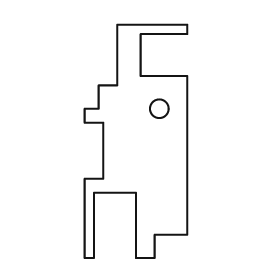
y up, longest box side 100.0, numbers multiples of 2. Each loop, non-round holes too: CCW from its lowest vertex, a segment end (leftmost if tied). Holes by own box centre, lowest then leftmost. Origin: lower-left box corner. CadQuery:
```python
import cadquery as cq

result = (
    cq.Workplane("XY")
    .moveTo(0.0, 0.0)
    .lineTo(4.0, 0.0)
    .lineTo(4.0, 28.0)
    .lineTo(22.0, 28.0)
    .lineTo(22.0, 0.0)
    .lineTo(30.0, 0.0)
    .lineTo(30.0, 10.0)
    .lineTo(44.0, 10.0)
    .lineTo(44.0, 78.0)
    .lineTo(24.0, 78.0)
    .lineTo(24.0, 96.0)
    .lineTo(44.0, 96.0)
    .lineTo(44.0, 100.0)
    .lineTo(14.0, 100.0)
    .lineTo(14.0, 74.0)
    .lineTo(6.0, 74.0)
    .lineTo(6.0, 64.0)
    .lineTo(0.0, 64.0)
    .lineTo(0.0, 58.0)
    .lineTo(8.0, 58.0)
    .lineTo(8.0, 34.0)
    .lineTo(0.0, 34.0)
    .close()
    .moveTo(32.0, 64.0)
    .circle(4.0)
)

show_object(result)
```